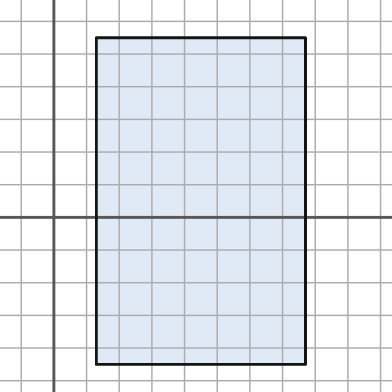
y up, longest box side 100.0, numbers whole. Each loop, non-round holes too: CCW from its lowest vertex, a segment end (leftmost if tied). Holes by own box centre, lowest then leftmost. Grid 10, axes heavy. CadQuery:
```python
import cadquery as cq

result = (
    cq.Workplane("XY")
    .moveTo(13.0, -45.0)
    .lineTo(77.0, -45.0)
    .lineTo(77.0, 55.0)
    .lineTo(13.0, 55.0)
    .close()
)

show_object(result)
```